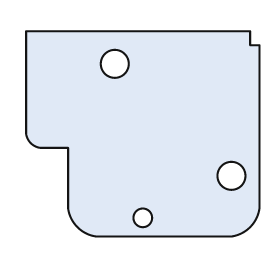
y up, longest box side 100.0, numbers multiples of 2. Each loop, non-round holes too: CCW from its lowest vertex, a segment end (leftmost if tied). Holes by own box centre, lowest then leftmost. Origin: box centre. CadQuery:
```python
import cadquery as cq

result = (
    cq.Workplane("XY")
    .moveTo(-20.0, -44.0)
    .lineTo(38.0, -44.0)
    .threePointArc((46.0, -40.0), (50.0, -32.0))
    .lineTo(50.0, 38.0)
    .lineTo(46.0, 38.0)
    .lineTo(46.0, 44.0)
    .lineTo(-50.0, 44.0)
    .lineTo(-50.0, 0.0)
    .threePointArc((-48.0, -4.0), (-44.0, -6.0))
    .lineTo(-32.0, -6.0)
    .lineTo(-32.0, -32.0)
    .threePointArc((-28.0, -40.0), (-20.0, -44.0))
    .close()
    .moveTo(0.0, -36.0)
    .circle(4.0)
    .moveTo(38.0, -18.0)
    .circle(6.0)
    .moveTo(-12.0, 30.0)
    .circle(6.0)
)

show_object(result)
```